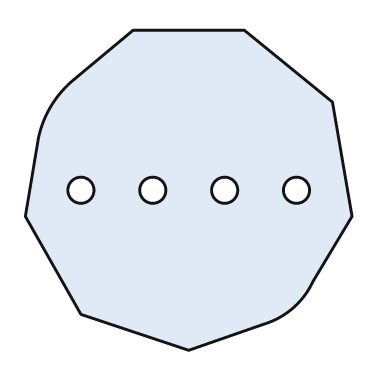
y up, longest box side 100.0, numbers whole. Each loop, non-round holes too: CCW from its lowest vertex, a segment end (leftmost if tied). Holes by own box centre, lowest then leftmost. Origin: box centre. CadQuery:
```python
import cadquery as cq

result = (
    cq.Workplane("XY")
    .moveTo(0.0, -49.0)
    .lineTo(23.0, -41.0)
    .threePointArc((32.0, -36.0), (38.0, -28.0))
    .lineTo(50.0, -8.0)
    .lineTo(44.0, 27.0)
    .lineTo(17.0, 49.0)
    .lineTo(-17.0, 49.0)
    .lineTo(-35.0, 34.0)
    .threePointArc((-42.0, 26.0), (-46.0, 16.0))
    .lineTo(-50.0, -8.0)
    .lineTo(-33.0, -38.0)
    .close()
    .moveTo(-33.0, 0.0)
    .circle(4.0)
    .moveTo(-11.0, 0.0)
    .circle(4.0)
    .moveTo(11.0, 0.0)
    .circle(4.0)
    .moveTo(33.0, 0.0)
    .circle(4.0)
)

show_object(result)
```